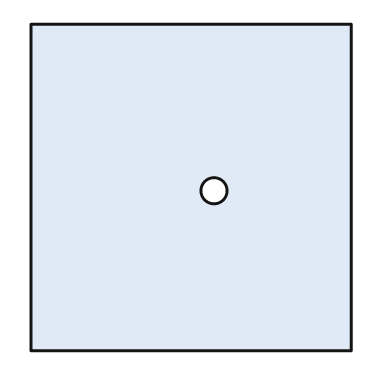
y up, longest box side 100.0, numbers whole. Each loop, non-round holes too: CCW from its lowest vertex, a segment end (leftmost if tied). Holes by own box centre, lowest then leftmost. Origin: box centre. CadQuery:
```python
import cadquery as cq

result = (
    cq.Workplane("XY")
    .moveTo(-49.0, -50.0)
    .lineTo(49.0, -50.0)
    .lineTo(49.0, 50.0)
    .lineTo(-49.0, 50.0)
    .close()
    .moveTo(7.0, -1.0)
    .circle(4.0)
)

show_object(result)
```